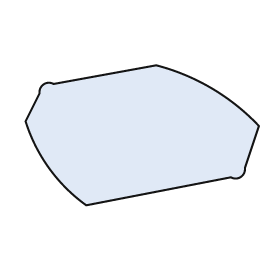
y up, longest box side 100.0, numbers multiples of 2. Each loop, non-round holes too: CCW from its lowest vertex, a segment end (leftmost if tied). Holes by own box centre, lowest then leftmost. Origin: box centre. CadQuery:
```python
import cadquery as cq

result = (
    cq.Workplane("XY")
    .moveTo(-24.0, -30.0)
    .lineTo(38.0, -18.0)
    .threePointArc((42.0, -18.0), (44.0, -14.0))
    .lineTo(50.0, 4.0)
    .threePointArc((30.0, 20.0), (6.0, 30.0))
    .lineTo(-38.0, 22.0)
    .threePointArc((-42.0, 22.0), (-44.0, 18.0))
    .lineTo(-50.0, 6.0)
    .threePointArc((-40.0, -14.0), (-24.0, -30.0))
    .close()
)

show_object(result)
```